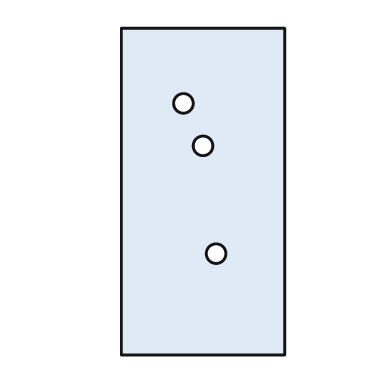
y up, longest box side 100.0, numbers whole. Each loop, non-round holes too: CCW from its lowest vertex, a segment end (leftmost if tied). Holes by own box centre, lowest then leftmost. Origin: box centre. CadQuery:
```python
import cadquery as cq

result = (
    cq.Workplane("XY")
    .moveTo(-25.0, -50.0)
    .lineTo(25.0, -50.0)
    .lineTo(25.0, 50.0)
    .lineTo(-25.0, 50.0)
    .close()
    .moveTo(4.0, -19.0)
    .circle(3.0)
    .moveTo(0.0, 14.0)
    .circle(3.0)
    .moveTo(-6.0, 27.0)
    .circle(3.0)
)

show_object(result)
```